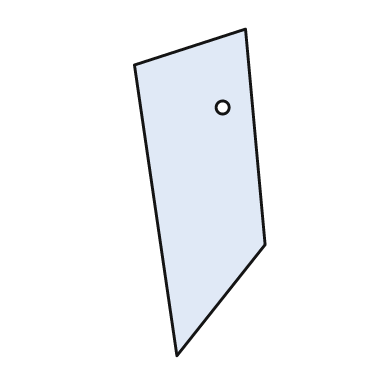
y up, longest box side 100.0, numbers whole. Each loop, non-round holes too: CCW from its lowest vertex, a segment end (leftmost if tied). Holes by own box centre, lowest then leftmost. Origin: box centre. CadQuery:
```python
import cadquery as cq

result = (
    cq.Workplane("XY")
    .moveTo(-7.0, -50.0)
    .lineTo(20.0, -16.0)
    .lineTo(14.0, 50.0)
    .lineTo(-20.0, 39.0)
    .close()
    .moveTo(7.0, 26.0)
    .circle(2.0)
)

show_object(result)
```